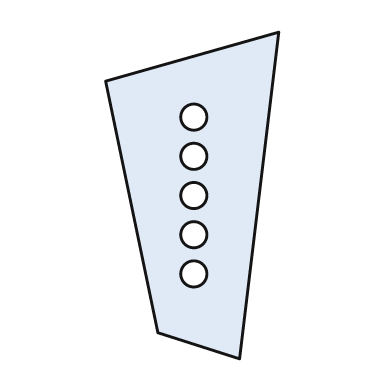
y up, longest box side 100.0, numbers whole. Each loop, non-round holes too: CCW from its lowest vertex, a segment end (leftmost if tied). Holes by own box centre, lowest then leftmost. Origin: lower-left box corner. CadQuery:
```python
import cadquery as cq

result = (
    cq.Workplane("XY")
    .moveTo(41.0, 0.0)
    .lineTo(53.0, 100.0)
    .lineTo(0.0, 85.0)
    .lineTo(16.0, 8.0)
    .close()
    .moveTo(27.0, 26.0)
    .circle(4.0)
    .moveTo(27.0, 38.0)
    .circle(4.0)
    .moveTo(27.0, 50.0)
    .circle(4.0)
    .moveTo(27.0, 62.0)
    .circle(4.0)
    .moveTo(27.0, 74.0)
    .circle(4.0)
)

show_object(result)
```